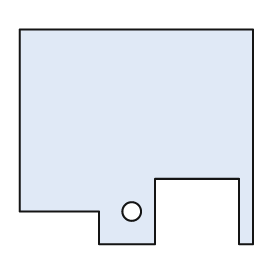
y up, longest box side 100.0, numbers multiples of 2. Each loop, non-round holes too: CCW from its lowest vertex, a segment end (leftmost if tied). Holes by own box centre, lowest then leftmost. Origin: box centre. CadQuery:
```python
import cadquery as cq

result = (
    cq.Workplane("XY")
    .moveTo(-16.0, -46.0)
    .lineTo(8.0, -46.0)
    .lineTo(8.0, -18.0)
    .lineTo(44.0, -18.0)
    .lineTo(44.0, -46.0)
    .lineTo(50.0, -46.0)
    .lineTo(50.0, 46.0)
    .lineTo(-50.0, 46.0)
    .lineTo(-50.0, -32.0)
    .lineTo(-16.0, -32.0)
    .close()
    .moveTo(-2.0, -32.0)
    .circle(4.0)
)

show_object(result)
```